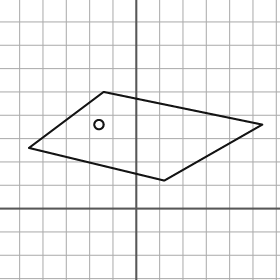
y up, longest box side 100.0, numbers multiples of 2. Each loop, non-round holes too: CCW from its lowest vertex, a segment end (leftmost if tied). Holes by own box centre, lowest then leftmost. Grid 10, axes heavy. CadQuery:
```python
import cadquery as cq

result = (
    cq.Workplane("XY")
    .moveTo(12.0, 12.0)
    .lineTo(54.0, 36.0)
    .lineTo(-14.0, 50.0)
    .lineTo(-46.0, 26.0)
    .close()
    .moveTo(-16.0, 36.0)
    .circle(2.0)
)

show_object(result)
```